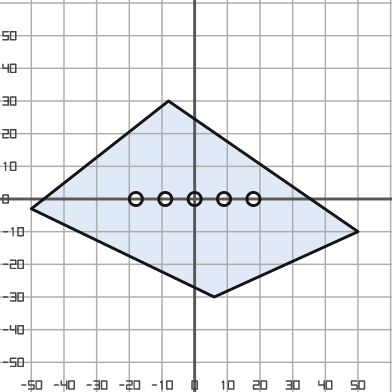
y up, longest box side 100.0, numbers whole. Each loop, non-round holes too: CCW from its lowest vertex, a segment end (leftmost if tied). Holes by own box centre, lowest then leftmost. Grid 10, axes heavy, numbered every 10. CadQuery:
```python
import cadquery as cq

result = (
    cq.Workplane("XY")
    .moveTo(6.0, -30.0)
    .lineTo(50.0, -10.0)
    .lineTo(-8.0, 30.0)
    .lineTo(-50.0, -3.0)
    .close()
    .moveTo(-18.0, 0.0)
    .circle(2.0)
    .moveTo(-9.0, 0.0)
    .circle(2.0)
    .moveTo(0.0, 0.0)
    .circle(2.0)
    .moveTo(9.0, 0.0)
    .circle(2.0)
    .moveTo(18.0, 0.0)
    .circle(2.0)
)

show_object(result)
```